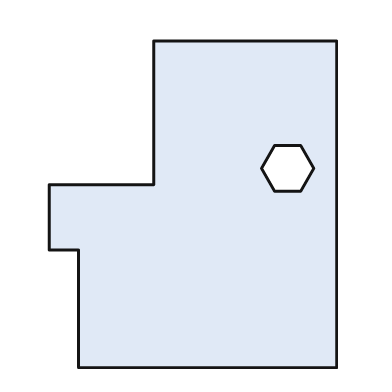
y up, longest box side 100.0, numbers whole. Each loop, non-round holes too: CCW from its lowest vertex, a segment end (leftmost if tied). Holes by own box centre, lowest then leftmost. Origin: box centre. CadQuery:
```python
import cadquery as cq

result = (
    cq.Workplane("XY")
    .moveTo(-35.0, -50.0)
    .lineTo(44.0, -50.0)
    .lineTo(44.0, 50.0)
    .lineTo(-12.0, 50.0)
    .lineTo(-12.0, 6.0)
    .lineTo(-44.0, 6.0)
    .lineTo(-44.0, -14.0)
    .lineTo(-35.0, -14.0)
    .close()
    .moveTo(25.0, 4.0)
    .lineTo(33.0, 4.0)
    .lineTo(37.0, 11.0)
    .lineTo(33.0, 18.0)
    .lineTo(25.0, 18.0)
    .lineTo(21.0, 11.0)
    .close()
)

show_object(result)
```